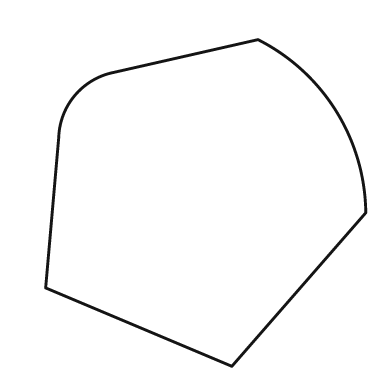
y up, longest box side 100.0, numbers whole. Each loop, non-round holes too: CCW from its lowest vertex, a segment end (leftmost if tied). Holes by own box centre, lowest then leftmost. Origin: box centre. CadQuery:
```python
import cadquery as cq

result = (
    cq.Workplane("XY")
    .moveTo(8.0, -50.0)
    .lineTo(49.0, -3.0)
    .threePointArc((40.0, 28.0), (16.0, 50.0))
    .lineTo(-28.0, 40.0)
    .threePointArc((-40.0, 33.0), (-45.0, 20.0))
    .lineTo(-49.0, -26.0)
    .close()
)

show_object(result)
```